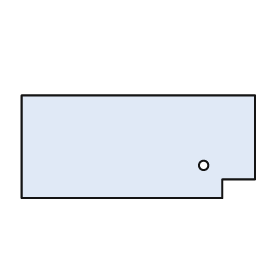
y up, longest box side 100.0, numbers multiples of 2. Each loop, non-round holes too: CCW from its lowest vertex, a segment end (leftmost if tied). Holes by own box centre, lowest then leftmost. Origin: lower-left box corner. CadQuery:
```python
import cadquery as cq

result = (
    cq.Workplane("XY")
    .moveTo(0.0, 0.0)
    .lineTo(86.0, 0.0)
    .lineTo(86.0, 8.0)
    .lineTo(100.0, 8.0)
    .lineTo(100.0, 44.0)
    .lineTo(0.0, 44.0)
    .close()
    .moveTo(78.0, 14.0)
    .circle(2.0)
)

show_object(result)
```